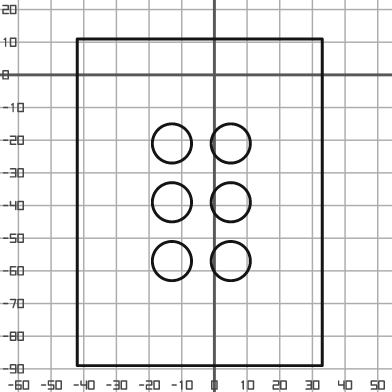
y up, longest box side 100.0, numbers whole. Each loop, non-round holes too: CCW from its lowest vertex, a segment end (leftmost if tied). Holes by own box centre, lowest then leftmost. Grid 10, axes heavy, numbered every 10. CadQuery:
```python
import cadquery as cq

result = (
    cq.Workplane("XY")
    .moveTo(-42.0, -89.0)
    .lineTo(33.0, -89.0)
    .lineTo(33.0, 11.0)
    .lineTo(-42.0, 11.0)
    .close()
    .moveTo(-13.0, -57.0)
    .circle(6.0)
    .moveTo(5.0, -57.0)
    .circle(6.0)
    .moveTo(-13.0, -39.0)
    .circle(6.0)
    .moveTo(5.0, -39.0)
    .circle(6.0)
    .moveTo(-13.0, -21.0)
    .circle(6.0)
    .moveTo(5.0, -21.0)
    .circle(6.0)
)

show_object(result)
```